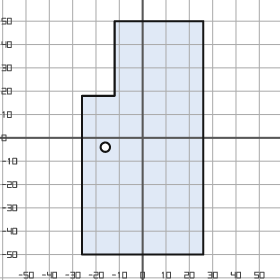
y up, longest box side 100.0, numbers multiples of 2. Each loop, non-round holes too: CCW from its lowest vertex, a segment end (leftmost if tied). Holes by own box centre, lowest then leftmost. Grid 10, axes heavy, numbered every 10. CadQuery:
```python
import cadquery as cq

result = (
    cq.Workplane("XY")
    .moveTo(-26.0, -50.0)
    .lineTo(26.0, -50.0)
    .lineTo(26.0, 50.0)
    .lineTo(-12.0, 50.0)
    .lineTo(-12.0, 18.0)
    .lineTo(-26.0, 18.0)
    .close()
    .moveTo(-16.0, -4.0)
    .circle(2.0)
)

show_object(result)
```